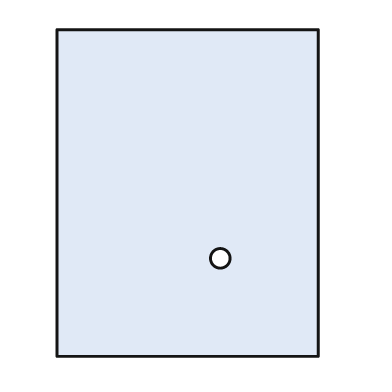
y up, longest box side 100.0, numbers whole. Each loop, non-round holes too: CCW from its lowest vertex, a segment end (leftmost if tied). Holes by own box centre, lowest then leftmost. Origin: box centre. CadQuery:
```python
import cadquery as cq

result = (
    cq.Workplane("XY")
    .moveTo(-40.0, -50.0)
    .lineTo(40.0, -50.0)
    .lineTo(40.0, 50.0)
    .lineTo(-40.0, 50.0)
    .close()
    .moveTo(10.0, -20.0)
    .circle(3.0)
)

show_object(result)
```